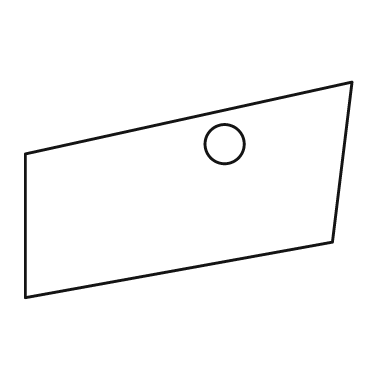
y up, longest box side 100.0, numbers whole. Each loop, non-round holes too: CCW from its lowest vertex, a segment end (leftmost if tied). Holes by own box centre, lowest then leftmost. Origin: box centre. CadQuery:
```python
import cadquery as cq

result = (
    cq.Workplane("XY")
    .moveTo(-50.0, -33.0)
    .lineTo(44.0, -16.0)
    .lineTo(50.0, 33.0)
    .lineTo(-50.0, 11.0)
    .close()
    .moveTo(11.0, 14.0)
    .circle(6.0)
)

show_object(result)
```